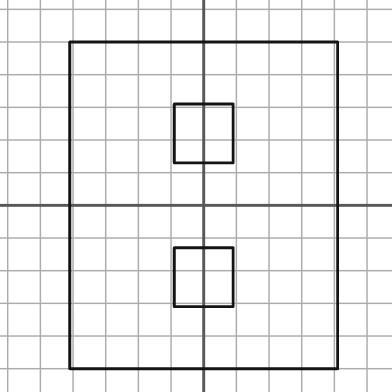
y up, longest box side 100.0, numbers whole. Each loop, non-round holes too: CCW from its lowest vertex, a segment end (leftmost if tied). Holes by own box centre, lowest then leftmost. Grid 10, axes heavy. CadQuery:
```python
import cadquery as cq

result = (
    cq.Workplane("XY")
    .moveTo(-41.0, -50.0)
    .lineTo(41.0, -50.0)
    .lineTo(41.0, 50.0)
    .lineTo(-41.0, 50.0)
    .close()
    .moveTo(-9.0, -31.0)
    .lineTo(9.0, -31.0)
    .lineTo(9.0, -13.0)
    .lineTo(-9.0, -13.0)
    .close()
    .moveTo(-9.0, 13.0)
    .lineTo(9.0, 13.0)
    .lineTo(9.0, 31.0)
    .lineTo(-9.0, 31.0)
    .close()
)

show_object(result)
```